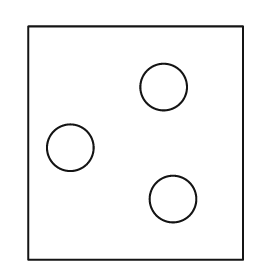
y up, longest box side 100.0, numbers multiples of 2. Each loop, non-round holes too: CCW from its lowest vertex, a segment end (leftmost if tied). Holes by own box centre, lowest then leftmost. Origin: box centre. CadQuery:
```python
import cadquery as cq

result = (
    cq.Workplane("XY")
    .moveTo(-46.0, -50.0)
    .lineTo(46.0, -50.0)
    .lineTo(46.0, 50.0)
    .lineTo(-46.0, 50.0)
    .close()
    .moveTo(16.0, -24.0)
    .circle(10.0)
    .moveTo(-28.0, -2.0)
    .circle(10.0)
    .moveTo(12.0, 24.0)
    .circle(10.0)
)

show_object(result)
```